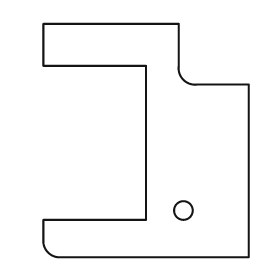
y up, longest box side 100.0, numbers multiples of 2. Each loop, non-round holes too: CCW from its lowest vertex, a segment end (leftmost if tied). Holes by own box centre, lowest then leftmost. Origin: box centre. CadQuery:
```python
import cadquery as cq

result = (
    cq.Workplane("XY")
    .moveTo(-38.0, -50.0)
    .lineTo(44.0, -50.0)
    .lineTo(44.0, 24.0)
    .lineTo(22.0, 24.0)
    .threePointArc((16.0, 26.0), (14.0, 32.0))
    .lineTo(14.0, 50.0)
    .lineTo(-44.0, 50.0)
    .lineTo(-44.0, 32.0)
    .lineTo(0.0, 32.0)
    .lineTo(0.0, -34.0)
    .lineTo(-44.0, -34.0)
    .lineTo(-44.0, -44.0)
    .threePointArc((-42.0, -48.0), (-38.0, -50.0))
    .close()
    .moveTo(16.0, -30.0)
    .circle(4.0)
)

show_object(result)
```